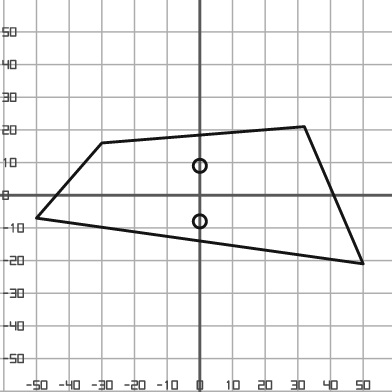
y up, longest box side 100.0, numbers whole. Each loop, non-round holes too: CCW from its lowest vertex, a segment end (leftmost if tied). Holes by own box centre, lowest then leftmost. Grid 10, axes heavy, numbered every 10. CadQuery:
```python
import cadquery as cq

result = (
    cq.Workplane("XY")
    .moveTo(50.0, -21.0)
    .lineTo(32.0, 21.0)
    .lineTo(-30.0, 16.0)
    .lineTo(-50.0, -7.0)
    .close()
    .moveTo(0.0, -8.0)
    .circle(2.0)
    .moveTo(0.0, 9.0)
    .circle(2.0)
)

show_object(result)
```